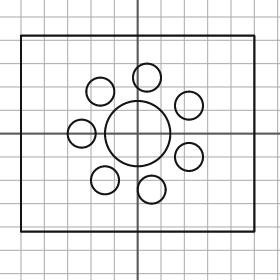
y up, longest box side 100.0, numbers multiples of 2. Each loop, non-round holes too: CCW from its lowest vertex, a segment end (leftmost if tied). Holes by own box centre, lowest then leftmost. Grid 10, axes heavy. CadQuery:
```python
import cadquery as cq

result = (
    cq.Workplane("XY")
    .moveTo(-50.0, -42.0)
    .lineTo(50.0, -42.0)
    .lineTo(50.0, 42.0)
    .lineTo(-50.0, 42.0)
    .close()
    .moveTo(6.0, -24.0)
    .circle(6.0)
    .moveTo(-14.0, -20.0)
    .circle(6.0)
    .moveTo(22.0, -10.0)
    .circle(6.0)
    .moveTo(-24.0, 0.0)
    .circle(6.0)
    .moveTo(0.0, 0.0)
    .circle(14.0)
    .moveTo(22.0, 12.0)
    .circle(6.0)
    .moveTo(-16.0, 18.0)
    .circle(6.0)
    .moveTo(4.0, 24.0)
    .circle(6.0)
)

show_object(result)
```